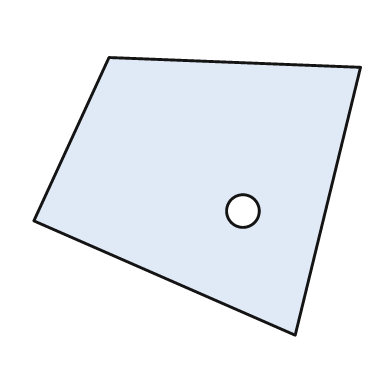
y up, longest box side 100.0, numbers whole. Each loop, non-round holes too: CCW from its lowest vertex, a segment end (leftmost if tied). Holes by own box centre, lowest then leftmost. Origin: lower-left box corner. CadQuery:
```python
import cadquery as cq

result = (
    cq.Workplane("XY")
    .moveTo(80.0, 0.0)
    .lineTo(100.0, 82.0)
    .lineTo(23.0, 85.0)
    .lineTo(0.0, 35.0)
    .close()
    .moveTo(64.0, 38.0)
    .circle(5.0)
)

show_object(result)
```